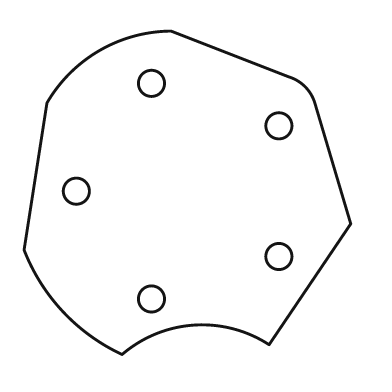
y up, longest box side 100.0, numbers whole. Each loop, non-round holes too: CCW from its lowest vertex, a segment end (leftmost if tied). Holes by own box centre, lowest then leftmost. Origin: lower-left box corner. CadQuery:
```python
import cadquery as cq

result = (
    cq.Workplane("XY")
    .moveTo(30.0, 0.0)
    .threePointArc((52.0, 9.0), (75.0, 3.0))
    .lineTo(100.0, 40.0)
    .lineTo(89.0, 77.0)
    .threePointArc((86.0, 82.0), (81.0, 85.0))
    .lineTo(45.0, 99.0)
    .threePointArc((23.0, 93.0), (7.0, 77.0))
    .lineTo(0.0, 32.0)
    .threePointArc((12.0, 13.0), (30.0, 0.0))
    .close()
    .moveTo(39.0, 17.0)
    .circle(4.0)
    .moveTo(78.0, 30.0)
    .circle(4.0)
    .moveTo(16.0, 50.0)
    .circle(4.0)
    .moveTo(78.0, 70.0)
    .circle(4.0)
    .moveTo(39.0, 83.0)
    .circle(4.0)
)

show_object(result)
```